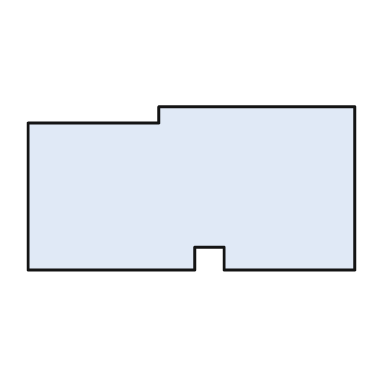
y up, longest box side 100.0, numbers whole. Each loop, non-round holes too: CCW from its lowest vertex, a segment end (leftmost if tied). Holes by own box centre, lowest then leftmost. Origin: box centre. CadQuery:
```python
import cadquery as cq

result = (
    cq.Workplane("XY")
    .moveTo(-50.0, -25.0)
    .lineTo(1.0, -25.0)
    .lineTo(1.0, -18.0)
    .lineTo(10.0, -18.0)
    .lineTo(10.0, -25.0)
    .lineTo(50.0, -25.0)
    .lineTo(50.0, 25.0)
    .lineTo(-10.0, 25.0)
    .lineTo(-10.0, 20.0)
    .lineTo(-50.0, 20.0)
    .close()
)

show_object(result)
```